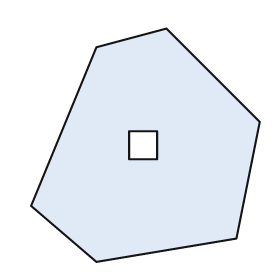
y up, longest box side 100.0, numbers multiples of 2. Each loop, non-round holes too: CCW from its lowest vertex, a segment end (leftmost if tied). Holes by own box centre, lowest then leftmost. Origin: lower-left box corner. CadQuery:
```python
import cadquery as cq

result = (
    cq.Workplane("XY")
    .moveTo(28.0, 0.0)
    .lineTo(88.0, 10.0)
    .lineTo(98.0, 60.0)
    .lineTo(58.0, 100.0)
    .lineTo(28.0, 92.0)
    .lineTo(0.0, 24.0)
    .close()
    .moveTo(42.0, 44.0)
    .lineTo(54.0, 44.0)
    .lineTo(54.0, 56.0)
    .lineTo(42.0, 56.0)
    .close()
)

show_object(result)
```